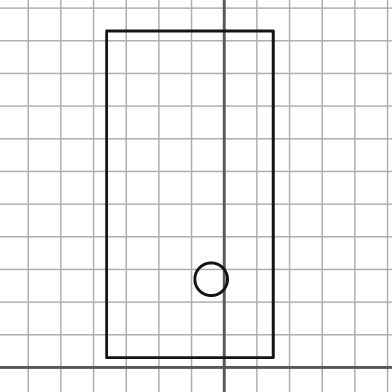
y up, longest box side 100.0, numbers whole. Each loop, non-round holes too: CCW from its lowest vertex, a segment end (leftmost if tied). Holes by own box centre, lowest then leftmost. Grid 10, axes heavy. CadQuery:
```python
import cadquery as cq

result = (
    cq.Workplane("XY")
    .moveTo(-36.0, 3.0)
    .lineTo(15.0, 3.0)
    .lineTo(15.0, 103.0)
    .lineTo(-36.0, 103.0)
    .close()
    .moveTo(-4.0, 27.0)
    .circle(5.0)
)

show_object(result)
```